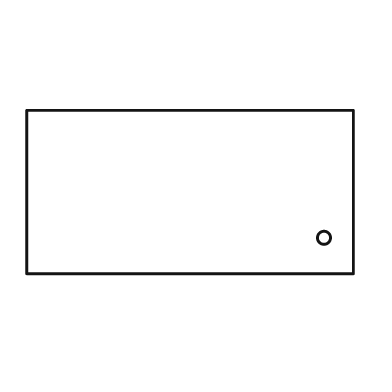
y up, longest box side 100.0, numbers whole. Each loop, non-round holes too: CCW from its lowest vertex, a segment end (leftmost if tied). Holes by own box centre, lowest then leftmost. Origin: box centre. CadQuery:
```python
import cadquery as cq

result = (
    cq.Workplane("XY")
    .moveTo(-50.0, -25.0)
    .lineTo(50.0, -25.0)
    .lineTo(50.0, 25.0)
    .lineTo(-50.0, 25.0)
    .close()
    .moveTo(41.0, -14.0)
    .circle(2.0)
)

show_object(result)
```